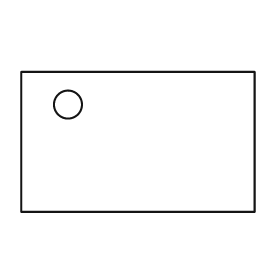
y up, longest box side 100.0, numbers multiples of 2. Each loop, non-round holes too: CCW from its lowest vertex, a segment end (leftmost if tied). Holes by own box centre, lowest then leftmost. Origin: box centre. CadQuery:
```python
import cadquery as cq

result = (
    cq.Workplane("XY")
    .moveTo(-50.0, -30.0)
    .lineTo(50.0, -30.0)
    .lineTo(50.0, 30.0)
    .lineTo(-50.0, 30.0)
    .close()
    .moveTo(-30.0, 16.0)
    .circle(6.0)
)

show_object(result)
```